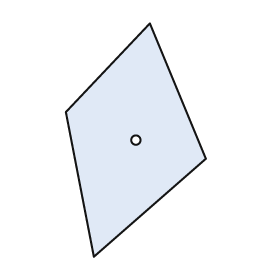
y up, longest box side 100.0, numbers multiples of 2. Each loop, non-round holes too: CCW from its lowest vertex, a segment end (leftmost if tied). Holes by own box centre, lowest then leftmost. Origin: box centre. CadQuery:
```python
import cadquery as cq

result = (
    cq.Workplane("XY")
    .moveTo(-18.0, -50.0)
    .lineTo(30.0, -8.0)
    .lineTo(6.0, 50.0)
    .lineTo(-30.0, 12.0)
    .close()
    .moveTo(0.0, 0.0)
    .circle(2.0)
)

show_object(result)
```